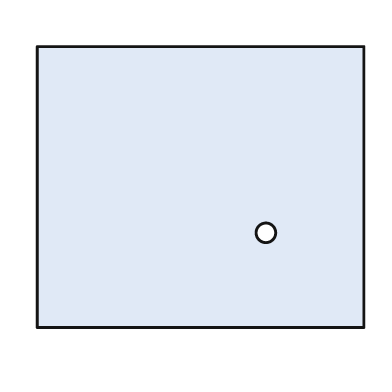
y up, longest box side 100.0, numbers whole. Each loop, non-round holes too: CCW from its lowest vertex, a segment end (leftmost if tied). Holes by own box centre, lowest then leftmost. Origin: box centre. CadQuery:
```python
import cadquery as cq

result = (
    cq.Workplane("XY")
    .moveTo(-50.0, -43.0)
    .lineTo(50.0, -43.0)
    .lineTo(50.0, 43.0)
    .lineTo(-50.0, 43.0)
    .close()
    .moveTo(20.0, -14.0)
    .circle(3.0)
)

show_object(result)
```